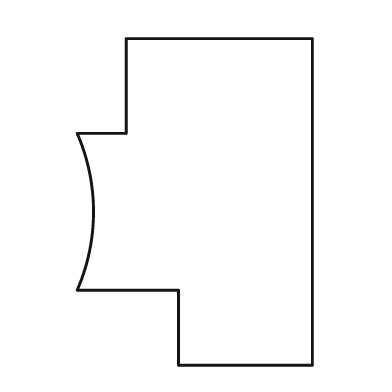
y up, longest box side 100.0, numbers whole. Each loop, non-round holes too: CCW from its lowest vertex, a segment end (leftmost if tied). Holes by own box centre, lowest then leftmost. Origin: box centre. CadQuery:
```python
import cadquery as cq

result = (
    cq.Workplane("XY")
    .moveTo(-5.0, -50.0)
    .lineTo(36.0, -50.0)
    .lineTo(36.0, 50.0)
    .lineTo(-21.0, 50.0)
    .lineTo(-21.0, 21.0)
    .lineTo(-36.0, 21.0)
    .threePointArc((-31.0, -3.0), (-36.0, -27.0))
    .lineTo(-5.0, -27.0)
    .close()
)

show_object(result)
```